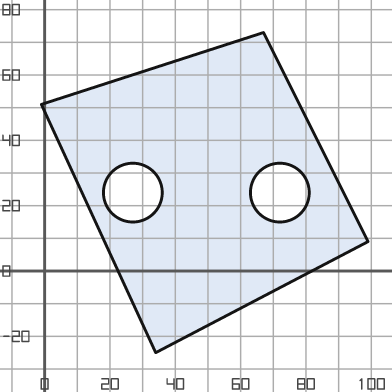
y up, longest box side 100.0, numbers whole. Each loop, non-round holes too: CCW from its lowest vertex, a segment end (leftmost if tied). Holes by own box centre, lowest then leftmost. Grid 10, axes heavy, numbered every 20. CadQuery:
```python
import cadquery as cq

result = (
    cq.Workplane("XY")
    .moveTo(34.0, -25.0)
    .lineTo(99.0, 9.0)
    .lineTo(67.0, 73.0)
    .lineTo(-1.0, 51.0)
    .close()
    .moveTo(27.0, 24.0)
    .circle(9.0)
    .moveTo(72.0, 24.0)
    .circle(9.0)
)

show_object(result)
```